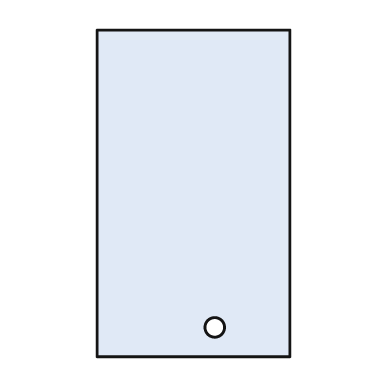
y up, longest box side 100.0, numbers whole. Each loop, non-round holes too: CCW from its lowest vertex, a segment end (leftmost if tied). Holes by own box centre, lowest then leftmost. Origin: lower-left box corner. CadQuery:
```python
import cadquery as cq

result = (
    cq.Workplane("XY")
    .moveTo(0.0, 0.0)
    .lineTo(59.0, 0.0)
    .lineTo(59.0, 100.0)
    .lineTo(0.0, 100.0)
    .close()
    .moveTo(36.0, 9.0)
    .circle(3.0)
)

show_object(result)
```